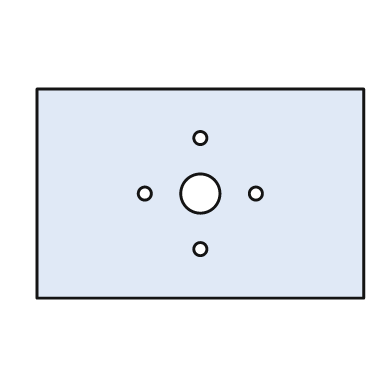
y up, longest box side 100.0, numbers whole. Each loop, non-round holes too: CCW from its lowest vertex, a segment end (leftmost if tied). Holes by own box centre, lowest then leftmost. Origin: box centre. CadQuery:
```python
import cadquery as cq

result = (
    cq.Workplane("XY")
    .moveTo(-50.0, -32.0)
    .lineTo(50.0, -32.0)
    .lineTo(50.0, 32.0)
    .lineTo(-50.0, 32.0)
    .close()
    .moveTo(0.0, -17.0)
    .circle(2.0)
    .moveTo(-17.0, 0.0)
    .circle(2.0)
    .moveTo(0.0, 0.0)
    .circle(6.0)
    .moveTo(17.0, 0.0)
    .circle(2.0)
    .moveTo(0.0, 17.0)
    .circle(2.0)
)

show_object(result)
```